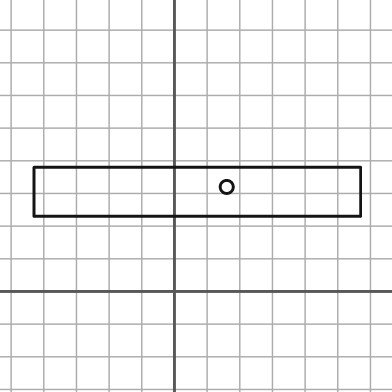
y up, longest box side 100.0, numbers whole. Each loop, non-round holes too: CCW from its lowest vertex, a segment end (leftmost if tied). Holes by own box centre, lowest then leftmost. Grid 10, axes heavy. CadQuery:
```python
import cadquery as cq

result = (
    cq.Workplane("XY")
    .moveTo(-43.0, 23.0)
    .lineTo(57.0, 23.0)
    .lineTo(57.0, 38.0)
    .lineTo(-43.0, 38.0)
    .close()
    .moveTo(16.0, 32.0)
    .circle(2.0)
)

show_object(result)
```